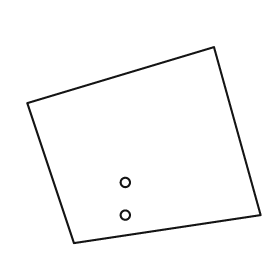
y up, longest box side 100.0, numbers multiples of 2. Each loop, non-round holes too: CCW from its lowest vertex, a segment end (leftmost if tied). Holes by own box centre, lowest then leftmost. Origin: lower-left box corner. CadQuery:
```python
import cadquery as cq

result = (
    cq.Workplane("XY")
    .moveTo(20.0, 0.0)
    .lineTo(100.0, 12.0)
    .lineTo(80.0, 84.0)
    .lineTo(0.0, 60.0)
    .close()
    .moveTo(42.0, 12.0)
    .circle(2.0)
    .moveTo(42.0, 26.0)
    .circle(2.0)
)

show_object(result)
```